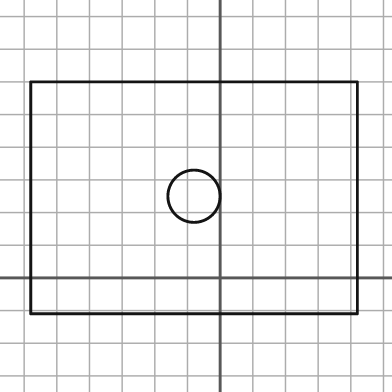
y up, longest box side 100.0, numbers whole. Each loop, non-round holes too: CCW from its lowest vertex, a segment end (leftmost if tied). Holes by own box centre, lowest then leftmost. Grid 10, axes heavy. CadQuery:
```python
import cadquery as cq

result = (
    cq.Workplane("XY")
    .moveTo(-58.0, -11.0)
    .lineTo(42.0, -11.0)
    .lineTo(42.0, 60.0)
    .lineTo(-58.0, 60.0)
    .close()
    .moveTo(-8.0, 25.0)
    .circle(8.0)
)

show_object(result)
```